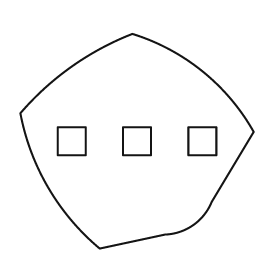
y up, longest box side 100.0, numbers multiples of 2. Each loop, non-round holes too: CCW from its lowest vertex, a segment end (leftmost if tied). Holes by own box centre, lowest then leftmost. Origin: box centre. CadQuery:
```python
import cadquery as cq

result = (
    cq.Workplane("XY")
    .moveTo(-16.0, -46.0)
    .lineTo(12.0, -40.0)
    .threePointArc((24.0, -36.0), (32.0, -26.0))
    .lineTo(50.0, 4.0)
    .threePointArc((28.0, 30.0), (-2.0, 46.0))
    .threePointArc((-28.0, 32.0), (-50.0, 12.0))
    .threePointArc((-38.0, -20.0), (-16.0, -46.0))
    .close()
    .moveTo(-34.0, -6.0)
    .lineTo(-22.0, -6.0)
    .lineTo(-22.0, 6.0)
    .lineTo(-34.0, 6.0)
    .close()
    .moveTo(-6.0, -6.0)
    .lineTo(6.0, -6.0)
    .lineTo(6.0, 6.0)
    .lineTo(-6.0, 6.0)
    .close()
    .moveTo(22.0, -6.0)
    .lineTo(34.0, -6.0)
    .lineTo(34.0, 6.0)
    .lineTo(22.0, 6.0)
    .close()
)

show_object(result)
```